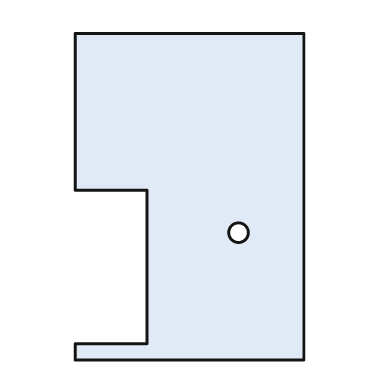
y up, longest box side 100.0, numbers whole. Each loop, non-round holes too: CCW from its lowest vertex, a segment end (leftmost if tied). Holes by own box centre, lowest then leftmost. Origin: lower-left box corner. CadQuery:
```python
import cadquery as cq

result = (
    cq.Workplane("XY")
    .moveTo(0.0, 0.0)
    .lineTo(70.0, 0.0)
    .lineTo(70.0, 100.0)
    .lineTo(0.0, 100.0)
    .lineTo(0.0, 52.0)
    .lineTo(22.0, 52.0)
    .lineTo(22.0, 5.0)
    .lineTo(0.0, 5.0)
    .close()
    .moveTo(50.0, 39.0)
    .circle(3.0)
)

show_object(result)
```